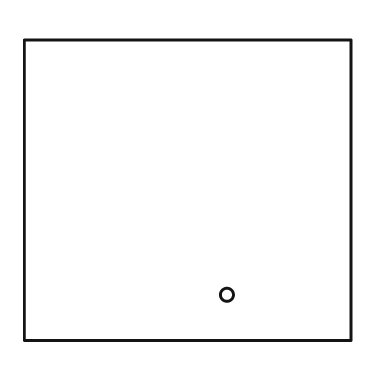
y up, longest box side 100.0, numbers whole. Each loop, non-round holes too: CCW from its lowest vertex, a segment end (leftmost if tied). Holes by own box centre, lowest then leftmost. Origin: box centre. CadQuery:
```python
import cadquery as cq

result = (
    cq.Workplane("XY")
    .moveTo(-50.0, -46.0)
    .lineTo(50.0, -46.0)
    .lineTo(50.0, 46.0)
    .lineTo(-50.0, 46.0)
    .close()
    .moveTo(12.0, -32.0)
    .circle(2.0)
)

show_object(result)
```